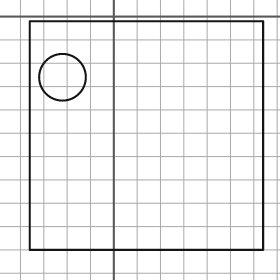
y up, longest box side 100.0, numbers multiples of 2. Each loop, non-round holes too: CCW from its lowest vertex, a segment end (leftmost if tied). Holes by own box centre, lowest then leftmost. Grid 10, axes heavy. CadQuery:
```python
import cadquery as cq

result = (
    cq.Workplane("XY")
    .moveTo(-36.0, -100.0)
    .lineTo(64.0, -100.0)
    .lineTo(64.0, -2.0)
    .lineTo(-36.0, -2.0)
    .close()
    .moveTo(-22.0, -26.0)
    .circle(10.0)
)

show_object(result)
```